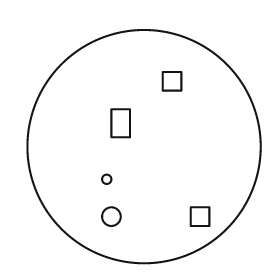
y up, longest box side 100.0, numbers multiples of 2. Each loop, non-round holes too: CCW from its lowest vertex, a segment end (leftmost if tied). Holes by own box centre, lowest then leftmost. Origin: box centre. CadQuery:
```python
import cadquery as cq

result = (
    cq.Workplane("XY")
    .moveTo(0.0, 0.0)
    .circle(50.0)
    .moveTo(-14.0, -30.0)
    .circle(4.0)
    .moveTo(20.0, -34.0)
    .lineTo(28.0, -34.0)
    .lineTo(28.0, -26.0)
    .lineTo(20.0, -26.0)
    .close()
    .moveTo(-16.0, -14.0)
    .circle(2.0)
    .moveTo(-14.0, 4.0)
    .lineTo(-6.0, 4.0)
    .lineTo(-6.0, 16.0)
    .lineTo(-14.0, 16.0)
    .close()
    .moveTo(8.0, 24.0)
    .lineTo(16.0, 24.0)
    .lineTo(16.0, 32.0)
    .lineTo(8.0, 32.0)
    .close()
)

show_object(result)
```